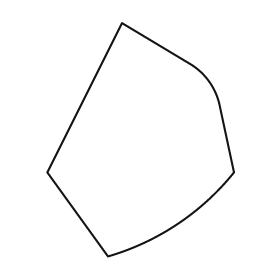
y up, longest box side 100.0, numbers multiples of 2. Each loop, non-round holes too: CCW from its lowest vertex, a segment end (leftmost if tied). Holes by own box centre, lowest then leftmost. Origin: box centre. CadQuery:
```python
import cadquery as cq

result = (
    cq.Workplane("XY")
    .moveTo(-14.0, -50.0)
    .threePointArc((16.0, -36.0), (40.0, -14.0))
    .lineTo(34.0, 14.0)
    .threePointArc((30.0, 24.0), (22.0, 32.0))
    .lineTo(-8.0, 50.0)
    .lineTo(-40.0, -14.0)
    .close()
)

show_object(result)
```